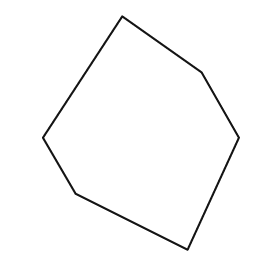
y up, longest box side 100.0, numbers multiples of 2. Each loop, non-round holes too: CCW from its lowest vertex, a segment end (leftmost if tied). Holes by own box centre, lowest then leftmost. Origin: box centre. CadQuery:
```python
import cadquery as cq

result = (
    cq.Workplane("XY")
    .moveTo(20.0, -50.0)
    .lineTo(42.0, -2.0)
    .lineTo(26.0, 26.0)
    .lineTo(-8.0, 50.0)
    .lineTo(-42.0, -2.0)
    .lineTo(-28.0, -26.0)
    .close()
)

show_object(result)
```